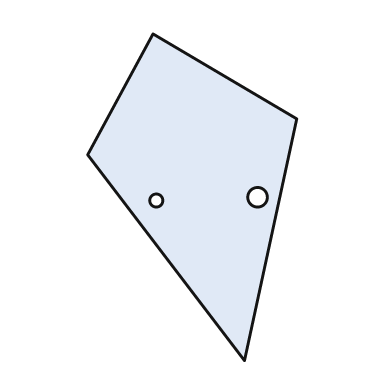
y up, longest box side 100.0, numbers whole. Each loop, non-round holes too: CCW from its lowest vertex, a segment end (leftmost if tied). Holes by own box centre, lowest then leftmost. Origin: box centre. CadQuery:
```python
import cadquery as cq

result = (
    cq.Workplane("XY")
    .moveTo(16.0, -50.0)
    .lineTo(32.0, 24.0)
    .lineTo(-12.0, 50.0)
    .lineTo(-32.0, 13.0)
    .close()
    .moveTo(-11.0, -1.0)
    .circle(2.0)
    .moveTo(20.0, 0.0)
    .circle(3.0)
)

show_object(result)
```